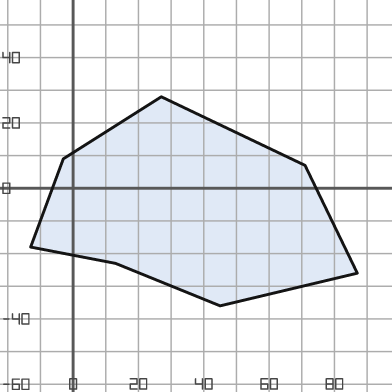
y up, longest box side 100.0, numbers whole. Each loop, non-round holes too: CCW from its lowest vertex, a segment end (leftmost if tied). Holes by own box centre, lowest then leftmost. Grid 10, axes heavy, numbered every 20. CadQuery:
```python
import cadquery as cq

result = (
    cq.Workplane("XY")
    .moveTo(45.0, -36.0)
    .lineTo(87.0, -26.0)
    .lineTo(71.0, 7.0)
    .lineTo(27.0, 28.0)
    .lineTo(-3.0, 9.0)
    .lineTo(-13.0, -18.0)
    .lineTo(13.0, -23.0)
    .close()
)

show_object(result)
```